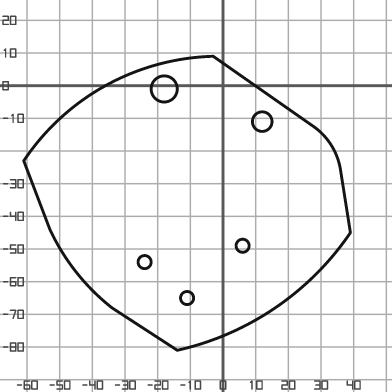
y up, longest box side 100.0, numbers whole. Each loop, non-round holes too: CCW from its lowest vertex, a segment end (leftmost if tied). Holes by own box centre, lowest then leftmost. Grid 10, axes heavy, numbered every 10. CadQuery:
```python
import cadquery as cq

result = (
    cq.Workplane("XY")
    .moveTo(-14.0, -81.0)
    .threePointArc((16.0, -68.0), (39.0, -45.0))
    .lineTo(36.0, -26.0)
    .threePointArc((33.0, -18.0), (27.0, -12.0))
    .lineTo(-3.0, 9.0)
    .threePointArc((-36.0, 0.0), (-61.0, -23.0))
    .lineTo(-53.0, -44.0)
    .threePointArc((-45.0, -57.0), (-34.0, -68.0))
    .close()
    .moveTo(-11.0, -65.0)
    .circle(2.0)
    .moveTo(-24.0, -54.0)
    .circle(2.0)
    .moveTo(6.0, -49.0)
    .circle(2.0)
    .moveTo(12.0, -11.0)
    .circle(3.0)
    .moveTo(-18.0, -1.0)
    .circle(4.0)
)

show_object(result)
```